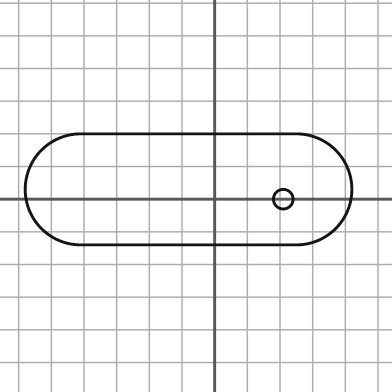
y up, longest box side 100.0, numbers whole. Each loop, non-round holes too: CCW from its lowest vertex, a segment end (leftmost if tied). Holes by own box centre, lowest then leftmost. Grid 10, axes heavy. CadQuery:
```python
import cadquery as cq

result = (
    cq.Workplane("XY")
    .moveTo(-41.0, -14.0)
    .lineTo(25.0, -14.0)
    .threePointArc((42.0, 3.0), (25.0, 20.0))
    .lineTo(-41.0, 20.0)
    .threePointArc((-58.0, 3.0), (-41.0, -14.0))
    .close()
    .moveTo(21.0, 0.0)
    .circle(3.0)
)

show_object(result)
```